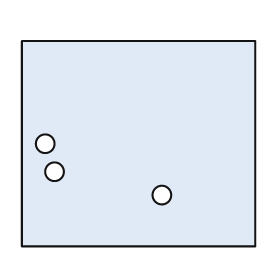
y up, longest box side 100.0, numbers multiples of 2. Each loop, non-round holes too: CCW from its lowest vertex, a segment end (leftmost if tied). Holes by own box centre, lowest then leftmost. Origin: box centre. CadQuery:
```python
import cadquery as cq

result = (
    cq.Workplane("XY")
    .moveTo(-50.0, -44.0)
    .lineTo(50.0, -44.0)
    .lineTo(50.0, 44.0)
    .lineTo(-50.0, 44.0)
    .close()
    .moveTo(10.0, -22.0)
    .circle(4.0)
    .moveTo(-36.0, -12.0)
    .circle(4.0)
    .moveTo(-40.0, 0.0)
    .circle(4.0)
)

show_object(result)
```